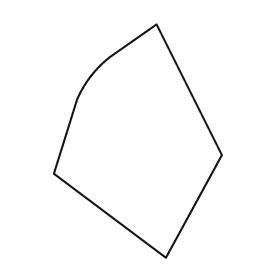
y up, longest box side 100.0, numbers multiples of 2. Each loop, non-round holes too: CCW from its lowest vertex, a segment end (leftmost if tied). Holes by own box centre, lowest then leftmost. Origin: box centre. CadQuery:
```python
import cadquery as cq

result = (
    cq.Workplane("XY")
    .moveTo(12.0, -50.0)
    .lineTo(36.0, -6.0)
    .lineTo(8.0, 50.0)
    .lineTo(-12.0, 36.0)
    .threePointArc((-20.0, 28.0), (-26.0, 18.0))
    .lineTo(-36.0, -14.0)
    .close()
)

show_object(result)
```